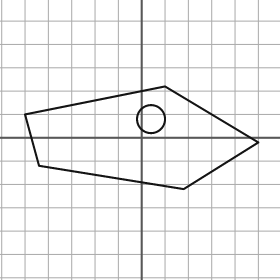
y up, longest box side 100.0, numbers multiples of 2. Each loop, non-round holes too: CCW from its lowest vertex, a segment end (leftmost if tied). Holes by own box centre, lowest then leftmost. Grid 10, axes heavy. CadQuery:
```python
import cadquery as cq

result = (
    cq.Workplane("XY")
    .moveTo(18.0, -22.0)
    .lineTo(50.0, -2.0)
    .lineTo(10.0, 22.0)
    .lineTo(-50.0, 10.0)
    .lineTo(-44.0, -12.0)
    .close()
    .moveTo(4.0, 8.0)
    .circle(6.0)
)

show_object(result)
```